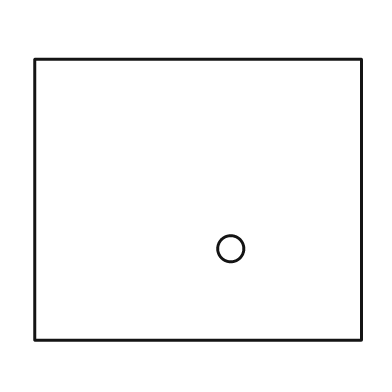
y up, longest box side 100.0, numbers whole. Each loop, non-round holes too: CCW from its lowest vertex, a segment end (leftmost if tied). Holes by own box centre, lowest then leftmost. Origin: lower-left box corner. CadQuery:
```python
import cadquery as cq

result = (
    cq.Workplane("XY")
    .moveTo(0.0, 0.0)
    .lineTo(100.0, 0.0)
    .lineTo(100.0, 86.0)
    .lineTo(0.0, 86.0)
    .close()
    .moveTo(60.0, 28.0)
    .circle(4.0)
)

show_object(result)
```